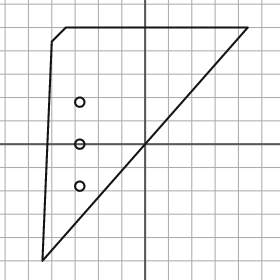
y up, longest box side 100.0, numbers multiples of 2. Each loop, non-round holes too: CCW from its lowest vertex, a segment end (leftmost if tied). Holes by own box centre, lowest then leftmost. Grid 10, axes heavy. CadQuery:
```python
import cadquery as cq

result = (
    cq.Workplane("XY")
    .moveTo(-44.0, -50.0)
    .lineTo(44.0, 50.0)
    .lineTo(-34.0, 50.0)
    .lineTo(-40.0, 44.0)
    .close()
    .moveTo(-28.0, -18.0)
    .circle(2.0)
    .moveTo(-28.0, 0.0)
    .circle(2.0)
    .moveTo(-28.0, 18.0)
    .circle(2.0)
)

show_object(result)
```